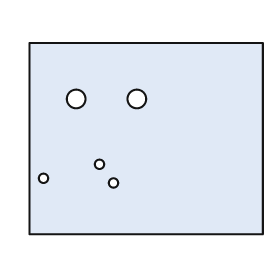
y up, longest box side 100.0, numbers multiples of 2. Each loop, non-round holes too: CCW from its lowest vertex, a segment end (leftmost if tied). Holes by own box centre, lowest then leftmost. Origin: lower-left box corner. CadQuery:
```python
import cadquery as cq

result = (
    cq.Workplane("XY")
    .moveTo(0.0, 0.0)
    .lineTo(100.0, 0.0)
    .lineTo(100.0, 82.0)
    .lineTo(0.0, 82.0)
    .close()
    .moveTo(36.0, 22.0)
    .circle(2.0)
    .moveTo(6.0, 24.0)
    .circle(2.0)
    .moveTo(30.0, 30.0)
    .circle(2.0)
    .moveTo(20.0, 58.0)
    .circle(4.0)
    .moveTo(46.0, 58.0)
    .circle(4.0)
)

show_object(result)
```